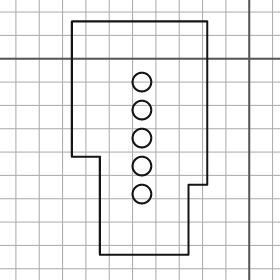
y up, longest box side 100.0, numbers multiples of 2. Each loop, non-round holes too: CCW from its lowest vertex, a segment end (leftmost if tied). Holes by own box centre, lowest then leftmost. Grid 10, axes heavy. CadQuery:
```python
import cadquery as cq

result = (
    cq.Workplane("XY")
    .moveTo(-64.0, -84.0)
    .lineTo(-26.0, -84.0)
    .lineTo(-26.0, -54.0)
    .lineTo(-18.0, -54.0)
    .lineTo(-18.0, 16.0)
    .lineTo(-76.0, 16.0)
    .lineTo(-76.0, -42.0)
    .lineTo(-64.0, -42.0)
    .close()
    .moveTo(-46.0, -58.0)
    .circle(4.0)
    .moveTo(-46.0, -46.0)
    .circle(4.0)
    .moveTo(-46.0, -34.0)
    .circle(4.0)
    .moveTo(-46.0, -22.0)
    .circle(4.0)
    .moveTo(-46.0, -10.0)
    .circle(4.0)
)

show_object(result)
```